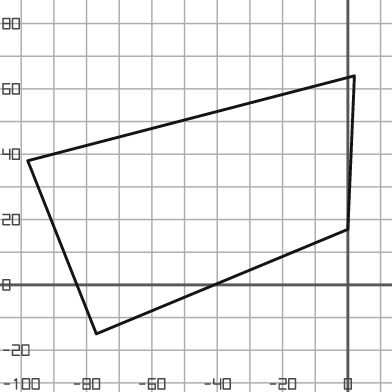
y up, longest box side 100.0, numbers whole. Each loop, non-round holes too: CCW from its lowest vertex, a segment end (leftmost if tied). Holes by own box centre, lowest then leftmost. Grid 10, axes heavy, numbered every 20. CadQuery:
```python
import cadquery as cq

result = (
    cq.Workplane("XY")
    .moveTo(-77.0, -15.0)
    .lineTo(0.0, 17.0)
    .lineTo(2.0, 64.0)
    .lineTo(-98.0, 38.0)
    .close()
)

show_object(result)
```